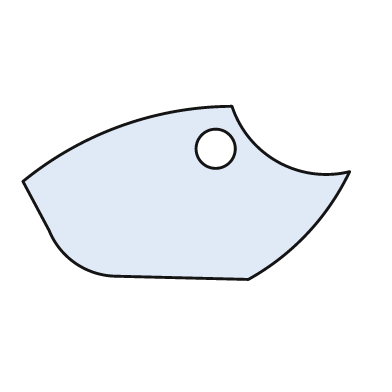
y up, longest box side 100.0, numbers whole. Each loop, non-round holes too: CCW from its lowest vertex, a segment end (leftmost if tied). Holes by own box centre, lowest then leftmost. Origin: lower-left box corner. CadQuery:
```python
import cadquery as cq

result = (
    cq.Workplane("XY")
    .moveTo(69.0, 0.0)
    .threePointArc((87.0, 14.0), (100.0, 33.0))
    .threePointArc((78.0, 36.0), (64.0, 53.0))
    .threePointArc((30.0, 47.0), (0.0, 30.0))
    .lineTo(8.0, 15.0)
    .threePointArc((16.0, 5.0), (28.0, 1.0))
    .close()
    .moveTo(59.0, 40.0)
    .circle(6.0)
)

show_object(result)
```